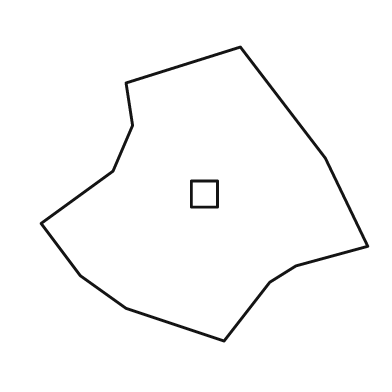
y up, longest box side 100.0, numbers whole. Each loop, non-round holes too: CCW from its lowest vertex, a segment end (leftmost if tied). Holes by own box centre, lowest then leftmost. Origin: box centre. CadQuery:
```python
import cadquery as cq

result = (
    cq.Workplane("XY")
    .moveTo(6.0, -45.0)
    .lineTo(20.0, -27.0)
    .lineTo(28.0, -22.0)
    .lineTo(50.0, -16.0)
    .lineTo(37.0, 11.0)
    .lineTo(11.0, 45.0)
    .lineTo(-24.0, 34.0)
    .lineTo(-22.0, 21.0)
    .lineTo(-28.0, 7.0)
    .lineTo(-50.0, -9.0)
    .lineTo(-38.0, -25.0)
    .lineTo(-24.0, -35.0)
    .close()
    .moveTo(-4.0, -4.0)
    .lineTo(4.0, -4.0)
    .lineTo(4.0, 4.0)
    .lineTo(-4.0, 4.0)
    .close()
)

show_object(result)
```